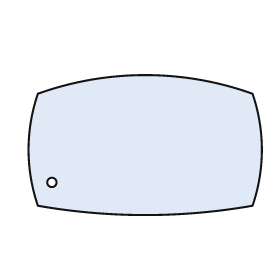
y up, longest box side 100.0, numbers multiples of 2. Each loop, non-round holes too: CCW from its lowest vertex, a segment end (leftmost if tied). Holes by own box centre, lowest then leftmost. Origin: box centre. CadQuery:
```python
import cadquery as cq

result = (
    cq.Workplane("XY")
    .moveTo(-46.0, -26.0)
    .threePointArc((0.0, -30.0), (46.0, -26.0))
    .threePointArc((50.0, -2.0), (46.0, 22.0))
    .threePointArc((0.0, 30.0), (-46.0, 22.0))
    .threePointArc((-50.0, -2.0), (-46.0, -26.0))
    .close()
    .moveTo(-40.0, -16.0)
    .circle(2.0)
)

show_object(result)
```